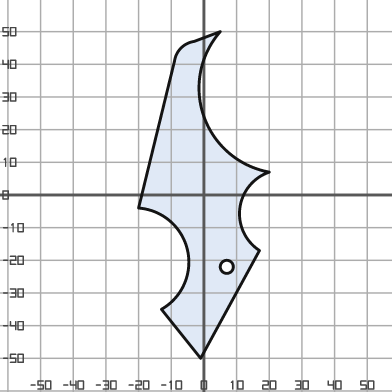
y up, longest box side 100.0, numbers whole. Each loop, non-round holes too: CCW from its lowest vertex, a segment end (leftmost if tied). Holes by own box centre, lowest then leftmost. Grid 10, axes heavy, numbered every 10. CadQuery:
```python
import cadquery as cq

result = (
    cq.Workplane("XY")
    .moveTo(-1.0, -50.0)
    .lineTo(17.0, -17.0)
    .threePointArc((11.0, -4.0), (20.0, 7.0))
    .threePointArc((0.0, 24.0), (5.0, 50.0))
    .lineTo(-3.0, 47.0)
    .threePointArc((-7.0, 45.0), (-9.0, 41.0))
    .lineTo(-20.0, -4.0)
    .threePointArc((-5.0, -17.0), (-13.0, -35.0))
    .close()
    .moveTo(7.0, -22.0)
    .circle(2.0)
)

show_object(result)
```